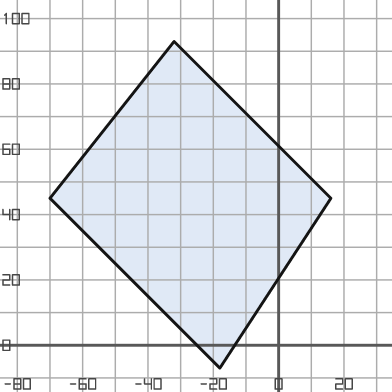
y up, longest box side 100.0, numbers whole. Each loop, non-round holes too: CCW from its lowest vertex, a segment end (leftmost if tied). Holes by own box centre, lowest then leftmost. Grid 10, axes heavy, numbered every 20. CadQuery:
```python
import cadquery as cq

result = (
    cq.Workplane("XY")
    .moveTo(-18.0, -7.0)
    .lineTo(16.0, 45.0)
    .lineTo(-32.0, 93.0)
    .lineTo(-70.0, 45.0)
    .close()
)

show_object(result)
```